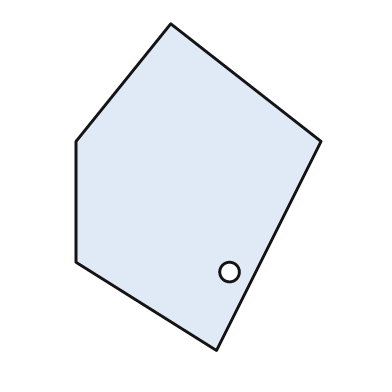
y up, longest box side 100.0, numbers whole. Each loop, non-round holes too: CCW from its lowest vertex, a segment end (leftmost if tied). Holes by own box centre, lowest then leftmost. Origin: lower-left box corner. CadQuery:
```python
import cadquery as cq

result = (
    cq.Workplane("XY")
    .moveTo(43.0, 0.0)
    .lineTo(75.0, 64.0)
    .lineTo(29.0, 100.0)
    .lineTo(0.0, 64.0)
    .lineTo(0.0, 27.0)
    .close()
    .moveTo(47.0, 24.0)
    .circle(3.0)
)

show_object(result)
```